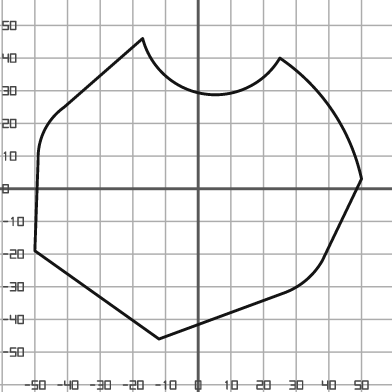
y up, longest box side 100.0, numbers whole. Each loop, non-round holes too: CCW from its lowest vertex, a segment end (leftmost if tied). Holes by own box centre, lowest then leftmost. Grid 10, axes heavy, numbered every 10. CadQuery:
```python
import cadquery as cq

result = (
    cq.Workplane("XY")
    .moveTo(-12.0, -46.0)
    .lineTo(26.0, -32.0)
    .threePointArc((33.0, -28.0), (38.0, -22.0))
    .lineTo(50.0, 3.0)
    .threePointArc((41.0, 24.0), (25.0, 40.0))
    .threePointArc((2.0, 29.0), (-17.0, 46.0))
    .lineTo(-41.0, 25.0)
    .threePointArc((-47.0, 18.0), (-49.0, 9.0))
    .lineTo(-50.0, -19.0)
    .close()
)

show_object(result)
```